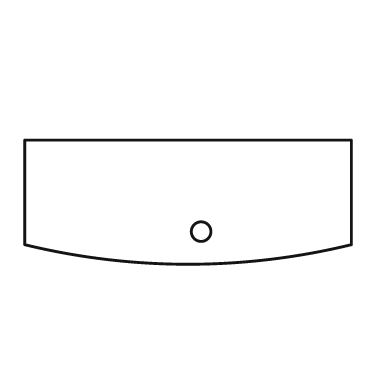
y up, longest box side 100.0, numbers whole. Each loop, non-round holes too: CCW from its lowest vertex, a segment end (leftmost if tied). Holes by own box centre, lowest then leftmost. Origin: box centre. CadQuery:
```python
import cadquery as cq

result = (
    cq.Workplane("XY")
    .moveTo(-50.0, -13.0)
    .threePointArc((0.0, -19.0), (50.0, -13.0))
    .lineTo(50.0, 19.0)
    .lineTo(-50.0, 19.0)
    .close()
    .moveTo(4.0, -9.0)
    .circle(3.0)
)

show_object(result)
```